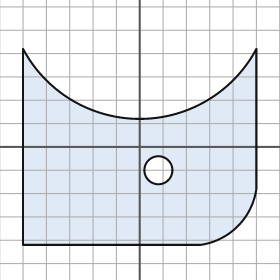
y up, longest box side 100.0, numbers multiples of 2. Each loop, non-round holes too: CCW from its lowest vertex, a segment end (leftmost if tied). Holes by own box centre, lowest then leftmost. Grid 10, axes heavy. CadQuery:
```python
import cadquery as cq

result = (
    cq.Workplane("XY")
    .moveTo(-50.0, -42.0)
    .lineTo(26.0, -42.0)
    .threePointArc((42.0, -34.0), (50.0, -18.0))
    .lineTo(50.0, 42.0)
    .threePointArc((0.0, 12.0), (-50.0, 42.0))
    .close()
    .moveTo(8.0, -10.0)
    .circle(6.0)
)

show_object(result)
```